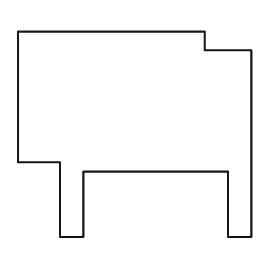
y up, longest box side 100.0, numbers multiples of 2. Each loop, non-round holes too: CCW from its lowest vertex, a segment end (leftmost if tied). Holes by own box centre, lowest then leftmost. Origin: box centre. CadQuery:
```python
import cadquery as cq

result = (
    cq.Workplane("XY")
    .moveTo(-32.0, -44.0)
    .lineTo(-22.0, -44.0)
    .lineTo(-22.0, -16.0)
    .lineTo(40.0, -16.0)
    .lineTo(40.0, -44.0)
    .lineTo(50.0, -44.0)
    .lineTo(50.0, 36.0)
    .lineTo(30.0, 36.0)
    .lineTo(30.0, 44.0)
    .lineTo(-50.0, 44.0)
    .lineTo(-50.0, -12.0)
    .lineTo(-32.0, -12.0)
    .close()
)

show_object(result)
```